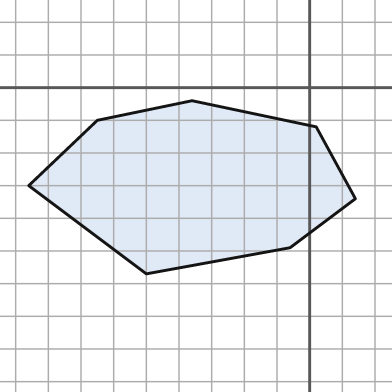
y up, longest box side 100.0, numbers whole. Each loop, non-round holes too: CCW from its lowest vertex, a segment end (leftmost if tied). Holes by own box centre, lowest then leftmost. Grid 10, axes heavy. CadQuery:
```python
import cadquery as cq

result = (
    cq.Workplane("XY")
    .moveTo(-50.0, -57.0)
    .lineTo(-6.0, -49.0)
    .lineTo(14.0, -34.0)
    .lineTo(2.0, -12.0)
    .lineTo(-36.0, -4.0)
    .lineTo(-65.0, -10.0)
    .lineTo(-86.0, -30.0)
    .close()
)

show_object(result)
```